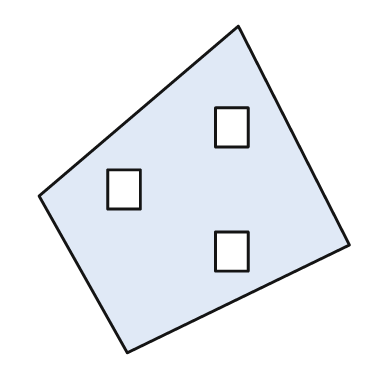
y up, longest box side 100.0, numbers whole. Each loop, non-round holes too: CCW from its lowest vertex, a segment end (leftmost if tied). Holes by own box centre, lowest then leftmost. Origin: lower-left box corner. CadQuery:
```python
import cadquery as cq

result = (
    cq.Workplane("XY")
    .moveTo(27.0, 0.0)
    .lineTo(95.0, 33.0)
    .lineTo(61.0, 100.0)
    .lineTo(0.0, 48.0)
    .close()
    .moveTo(54.0, 25.0)
    .lineTo(64.0, 25.0)
    .lineTo(64.0, 37.0)
    .lineTo(54.0, 37.0)
    .close()
    .moveTo(21.0, 44.0)
    .lineTo(31.0, 44.0)
    .lineTo(31.0, 56.0)
    .lineTo(21.0, 56.0)
    .close()
    .moveTo(54.0, 63.0)
    .lineTo(64.0, 63.0)
    .lineTo(64.0, 75.0)
    .lineTo(54.0, 75.0)
    .close()
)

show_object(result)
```